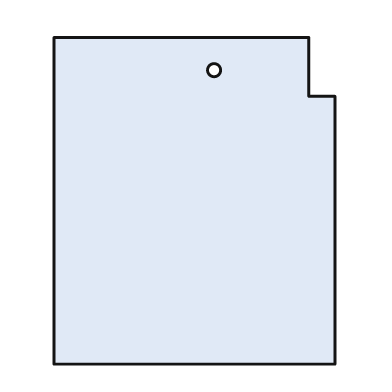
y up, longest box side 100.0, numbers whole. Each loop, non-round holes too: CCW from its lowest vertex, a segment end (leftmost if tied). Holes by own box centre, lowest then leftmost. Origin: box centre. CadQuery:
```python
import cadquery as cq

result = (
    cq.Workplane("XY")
    .moveTo(-43.0, -50.0)
    .lineTo(43.0, -50.0)
    .lineTo(43.0, 32.0)
    .lineTo(35.0, 32.0)
    .lineTo(35.0, 50.0)
    .lineTo(-43.0, 50.0)
    .close()
    .moveTo(6.0, 40.0)
    .circle(2.0)
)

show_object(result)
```